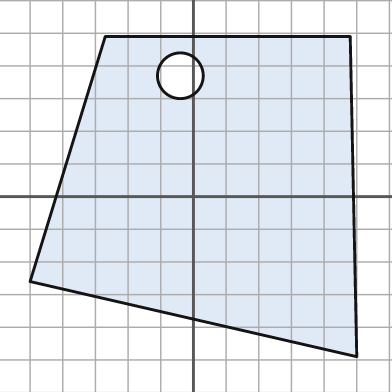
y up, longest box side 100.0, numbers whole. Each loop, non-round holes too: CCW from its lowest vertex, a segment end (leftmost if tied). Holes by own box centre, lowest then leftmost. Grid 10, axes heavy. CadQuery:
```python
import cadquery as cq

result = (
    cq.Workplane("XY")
    .moveTo(50.0, -49.0)
    .lineTo(48.0, 49.0)
    .lineTo(-27.0, 49.0)
    .lineTo(-50.0, -26.0)
    .close()
    .moveTo(-4.0, 37.0)
    .circle(7.0)
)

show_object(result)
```